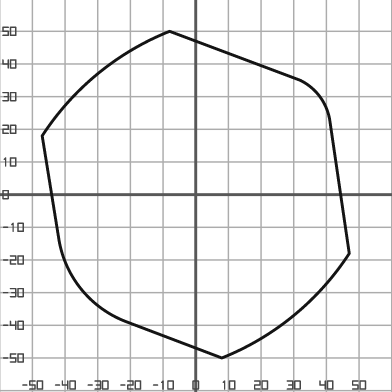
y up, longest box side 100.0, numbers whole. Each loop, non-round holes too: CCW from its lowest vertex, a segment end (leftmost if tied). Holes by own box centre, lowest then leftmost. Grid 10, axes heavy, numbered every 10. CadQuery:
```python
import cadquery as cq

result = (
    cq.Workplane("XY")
    .moveTo(8.0, -50.0)
    .threePointArc((30.0, -37.0), (47.0, -18.0))
    .lineTo(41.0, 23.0)
    .threePointArc((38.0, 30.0), (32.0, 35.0))
    .lineTo(-8.0, 50.0)
    .threePointArc((-30.0, 37.0), (-47.0, 18.0))
    .lineTo(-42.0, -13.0)
    .threePointArc((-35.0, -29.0), (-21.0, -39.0))
    .close()
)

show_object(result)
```